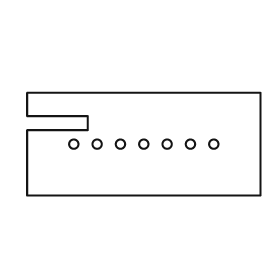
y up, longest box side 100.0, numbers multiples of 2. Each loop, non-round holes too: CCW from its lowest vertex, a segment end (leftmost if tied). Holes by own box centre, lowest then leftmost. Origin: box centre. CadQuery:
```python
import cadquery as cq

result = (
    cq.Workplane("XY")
    .moveTo(-50.0, -22.0)
    .lineTo(50.0, -22.0)
    .lineTo(50.0, 22.0)
    .lineTo(-50.0, 22.0)
    .lineTo(-50.0, 12.0)
    .lineTo(-24.0, 12.0)
    .lineTo(-24.0, 6.0)
    .lineTo(-50.0, 6.0)
    .close()
    .moveTo(-30.0, 0.0)
    .circle(2.0)
    .moveTo(-20.0, 0.0)
    .circle(2.0)
    .moveTo(-10.0, 0.0)
    .circle(2.0)
    .moveTo(0.0, 0.0)
    .circle(2.0)
    .moveTo(10.0, 0.0)
    .circle(2.0)
    .moveTo(20.0, 0.0)
    .circle(2.0)
    .moveTo(30.0, 0.0)
    .circle(2.0)
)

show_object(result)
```